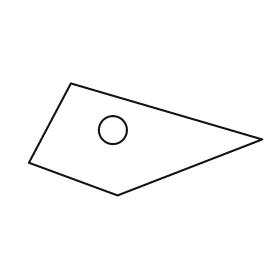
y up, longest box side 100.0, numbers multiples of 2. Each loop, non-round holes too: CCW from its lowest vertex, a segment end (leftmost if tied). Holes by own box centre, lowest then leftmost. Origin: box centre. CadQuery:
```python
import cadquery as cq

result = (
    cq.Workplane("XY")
    .moveTo(-12.0, -24.0)
    .lineTo(50.0, 0.0)
    .lineTo(-32.0, 24.0)
    .lineTo(-50.0, -10.0)
    .close()
    .moveTo(-14.0, 4.0)
    .circle(6.0)
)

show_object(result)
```